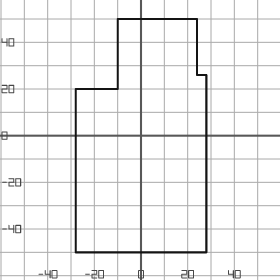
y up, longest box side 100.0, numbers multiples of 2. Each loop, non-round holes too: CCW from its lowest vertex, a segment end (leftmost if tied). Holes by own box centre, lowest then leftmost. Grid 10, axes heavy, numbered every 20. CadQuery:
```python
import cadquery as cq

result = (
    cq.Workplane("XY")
    .moveTo(-28.0, -50.0)
    .lineTo(28.0, -50.0)
    .lineTo(28.0, 26.0)
    .lineTo(24.0, 26.0)
    .lineTo(24.0, 50.0)
    .lineTo(-10.0, 50.0)
    .lineTo(-10.0, 20.0)
    .lineTo(-28.0, 20.0)
    .close()
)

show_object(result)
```